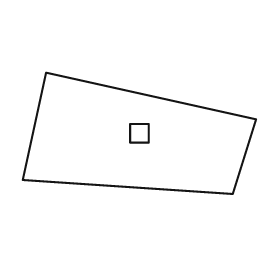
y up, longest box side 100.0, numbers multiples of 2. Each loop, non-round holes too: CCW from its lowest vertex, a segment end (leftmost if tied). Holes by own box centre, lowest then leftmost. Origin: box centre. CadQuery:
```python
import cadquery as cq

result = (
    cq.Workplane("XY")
    .moveTo(40.0, -26.0)
    .lineTo(50.0, 6.0)
    .lineTo(-40.0, 26.0)
    .lineTo(-50.0, -20.0)
    .close()
    .moveTo(-4.0, -4.0)
    .lineTo(4.0, -4.0)
    .lineTo(4.0, 4.0)
    .lineTo(-4.0, 4.0)
    .close()
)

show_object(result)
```